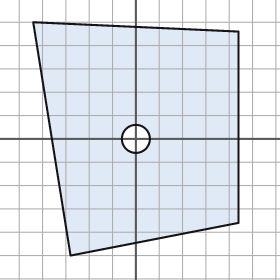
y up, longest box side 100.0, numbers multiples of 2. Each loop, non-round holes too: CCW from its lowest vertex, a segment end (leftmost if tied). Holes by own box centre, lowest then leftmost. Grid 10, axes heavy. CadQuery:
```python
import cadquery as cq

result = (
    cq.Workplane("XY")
    .moveTo(-28.0, -50.0)
    .lineTo(44.0, -36.0)
    .lineTo(44.0, 46.0)
    .lineTo(-44.0, 50.0)
    .close()
    .moveTo(0.0, 0.0)
    .circle(6.0)
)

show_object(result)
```